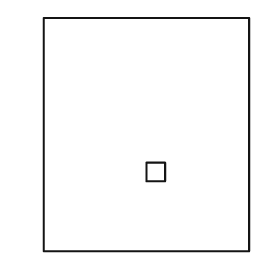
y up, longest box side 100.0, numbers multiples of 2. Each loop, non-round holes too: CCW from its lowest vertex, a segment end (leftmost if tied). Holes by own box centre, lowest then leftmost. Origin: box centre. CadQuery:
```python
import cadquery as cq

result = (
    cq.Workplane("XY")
    .moveTo(-44.0, -50.0)
    .lineTo(44.0, -50.0)
    .lineTo(44.0, 50.0)
    .lineTo(-44.0, 50.0)
    .close()
    .moveTo(0.0, -20.0)
    .lineTo(8.0, -20.0)
    .lineTo(8.0, -12.0)
    .lineTo(0.0, -12.0)
    .close()
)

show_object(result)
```